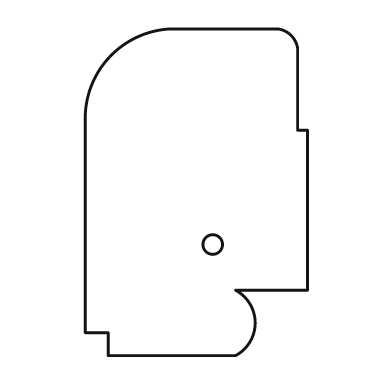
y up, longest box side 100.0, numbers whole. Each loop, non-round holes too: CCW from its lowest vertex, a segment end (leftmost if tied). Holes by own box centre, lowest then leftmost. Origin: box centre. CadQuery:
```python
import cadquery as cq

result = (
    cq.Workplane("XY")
    .moveTo(-27.0, -50.0)
    .lineTo(12.0, -50.0)
    .threePointArc((18.0, -40.0), (12.0, -30.0))
    .lineTo(34.0, -30.0)
    .lineTo(34.0, 19.0)
    .lineTo(31.0, 19.0)
    .lineTo(31.0, 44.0)
    .threePointArc((29.0, 48.0), (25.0, 50.0))
    .lineTo(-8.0, 50.0)
    .threePointArc((-26.0, 42.0), (-34.0, 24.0))
    .lineTo(-34.0, -43.0)
    .lineTo(-27.0, -43.0)
    .close()
    .moveTo(5.0, -16.0)
    .circle(3.0)
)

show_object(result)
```